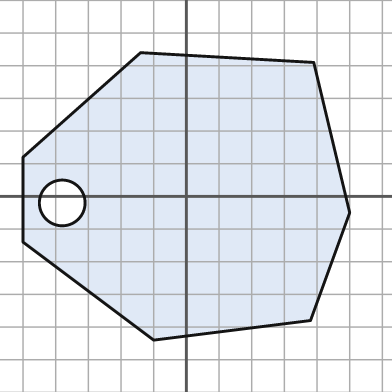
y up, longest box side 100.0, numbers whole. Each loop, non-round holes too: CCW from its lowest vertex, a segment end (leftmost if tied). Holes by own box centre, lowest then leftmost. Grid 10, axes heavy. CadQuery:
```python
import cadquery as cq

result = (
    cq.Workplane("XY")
    .moveTo(-10.0, -44.0)
    .lineTo(38.0, -38.0)
    .lineTo(50.0, -5.0)
    .lineTo(39.0, 41.0)
    .lineTo(-14.0, 44.0)
    .lineTo(-50.0, 12.0)
    .lineTo(-50.0, -14.0)
    .close()
    .moveTo(-38.0, -2.0)
    .circle(7.0)
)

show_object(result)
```